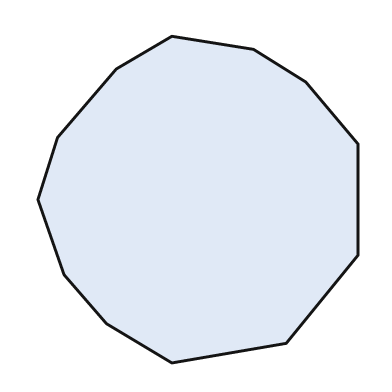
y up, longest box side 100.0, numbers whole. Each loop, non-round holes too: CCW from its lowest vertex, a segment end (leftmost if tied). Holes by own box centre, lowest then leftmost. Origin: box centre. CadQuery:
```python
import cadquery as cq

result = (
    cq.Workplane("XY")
    .moveTo(-8.0, -50.0)
    .lineTo(27.0, -44.0)
    .lineTo(49.0, -17.0)
    .lineTo(49.0, 17.0)
    .lineTo(33.0, 36.0)
    .lineTo(17.0, 46.0)
    .lineTo(-8.0, 50.0)
    .lineTo(-25.0, 40.0)
    .lineTo(-43.0, 19.0)
    .lineTo(-49.0, 0.0)
    .lineTo(-41.0, -23.0)
    .lineTo(-28.0, -38.0)
    .close()
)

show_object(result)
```